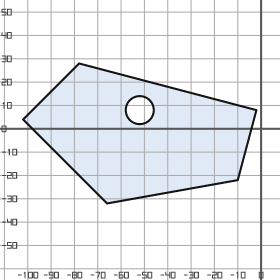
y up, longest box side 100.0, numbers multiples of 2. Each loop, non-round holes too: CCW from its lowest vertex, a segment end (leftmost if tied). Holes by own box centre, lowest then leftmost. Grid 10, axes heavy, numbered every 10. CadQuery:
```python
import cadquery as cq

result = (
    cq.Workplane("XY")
    .moveTo(-66.0, -32.0)
    .lineTo(-10.0, -22.0)
    .lineTo(-2.0, 8.0)
    .lineTo(-78.0, 28.0)
    .lineTo(-102.0, 4.0)
    .close()
    .moveTo(-52.0, 8.0)
    .circle(6.0)
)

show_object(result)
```